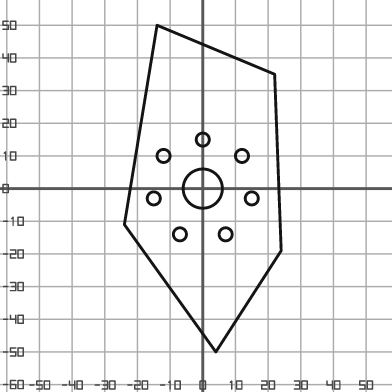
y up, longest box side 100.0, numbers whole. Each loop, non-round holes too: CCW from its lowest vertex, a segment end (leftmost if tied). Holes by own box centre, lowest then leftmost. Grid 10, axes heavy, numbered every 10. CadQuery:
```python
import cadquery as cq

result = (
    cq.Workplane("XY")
    .moveTo(4.0, -50.0)
    .lineTo(24.0, -19.0)
    .lineTo(22.0, 35.0)
    .lineTo(-14.0, 50.0)
    .lineTo(-24.0, -11.0)
    .close()
    .moveTo(-7.0, -14.0)
    .circle(2.0)
    .moveTo(7.0, -14.0)
    .circle(2.0)
    .moveTo(-15.0, -3.0)
    .circle(2.0)
    .moveTo(15.0, -3.0)
    .circle(2.0)
    .moveTo(0.0, 0.0)
    .circle(6.0)
    .moveTo(-12.0, 10.0)
    .circle(2.0)
    .moveTo(12.0, 10.0)
    .circle(2.0)
    .moveTo(0.0, 15.0)
    .circle(2.0)
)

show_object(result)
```